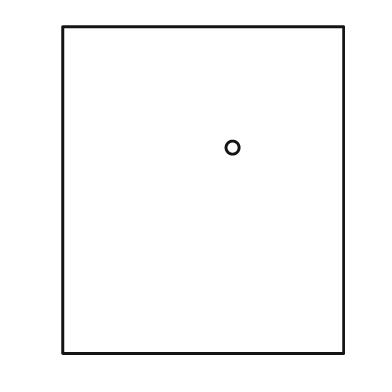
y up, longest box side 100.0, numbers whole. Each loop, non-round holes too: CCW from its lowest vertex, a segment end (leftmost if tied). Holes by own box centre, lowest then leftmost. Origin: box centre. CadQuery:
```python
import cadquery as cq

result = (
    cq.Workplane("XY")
    .moveTo(-43.0, -50.0)
    .lineTo(43.0, -50.0)
    .lineTo(43.0, 50.0)
    .lineTo(-43.0, 50.0)
    .close()
    .moveTo(9.0, 13.0)
    .circle(2.0)
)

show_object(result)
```